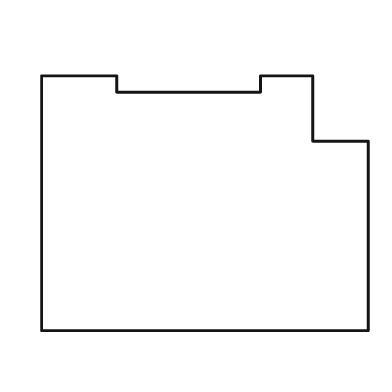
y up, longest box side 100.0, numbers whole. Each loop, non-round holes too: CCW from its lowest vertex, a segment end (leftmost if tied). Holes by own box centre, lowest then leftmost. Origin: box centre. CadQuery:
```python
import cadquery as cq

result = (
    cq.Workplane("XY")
    .moveTo(-50.0, -39.0)
    .lineTo(50.0, -39.0)
    .lineTo(50.0, 19.0)
    .lineTo(33.0, 19.0)
    .lineTo(33.0, 39.0)
    .lineTo(17.0, 39.0)
    .lineTo(17.0, 34.0)
    .lineTo(-27.0, 34.0)
    .lineTo(-27.0, 39.0)
    .lineTo(-50.0, 39.0)
    .close()
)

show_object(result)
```